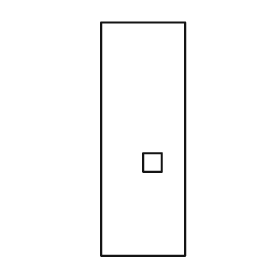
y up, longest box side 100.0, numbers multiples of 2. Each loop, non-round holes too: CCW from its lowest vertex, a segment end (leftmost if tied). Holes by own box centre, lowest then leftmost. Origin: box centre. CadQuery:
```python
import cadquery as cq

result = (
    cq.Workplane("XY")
    .moveTo(-18.0, -50.0)
    .lineTo(18.0, -50.0)
    .lineTo(18.0, 50.0)
    .lineTo(-18.0, 50.0)
    .close()
    .moveTo(0.0, -14.0)
    .lineTo(8.0, -14.0)
    .lineTo(8.0, -6.0)
    .lineTo(0.0, -6.0)
    .close()
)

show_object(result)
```